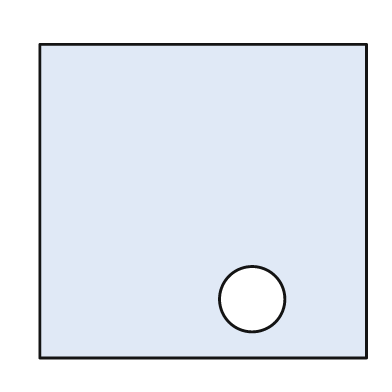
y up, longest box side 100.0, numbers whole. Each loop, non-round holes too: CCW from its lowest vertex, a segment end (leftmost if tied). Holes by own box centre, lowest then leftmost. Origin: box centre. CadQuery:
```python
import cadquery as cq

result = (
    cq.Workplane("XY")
    .moveTo(-50.0, -48.0)
    .lineTo(50.0, -48.0)
    .lineTo(50.0, 48.0)
    .lineTo(-50.0, 48.0)
    .close()
    .moveTo(15.0, -30.0)
    .circle(10.0)
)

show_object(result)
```